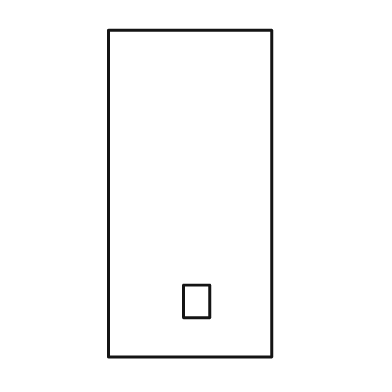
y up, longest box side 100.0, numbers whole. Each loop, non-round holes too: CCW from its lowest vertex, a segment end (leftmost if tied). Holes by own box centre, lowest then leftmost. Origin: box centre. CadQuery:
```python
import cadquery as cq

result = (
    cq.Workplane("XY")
    .moveTo(-25.0, -50.0)
    .lineTo(25.0, -50.0)
    .lineTo(25.0, 50.0)
    .lineTo(-25.0, 50.0)
    .close()
    .moveTo(-2.0, -38.0)
    .lineTo(6.0, -38.0)
    .lineTo(6.0, -28.0)
    .lineTo(-2.0, -28.0)
    .close()
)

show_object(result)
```